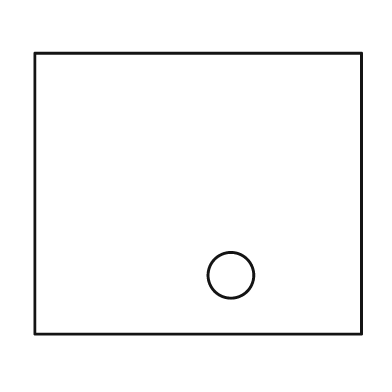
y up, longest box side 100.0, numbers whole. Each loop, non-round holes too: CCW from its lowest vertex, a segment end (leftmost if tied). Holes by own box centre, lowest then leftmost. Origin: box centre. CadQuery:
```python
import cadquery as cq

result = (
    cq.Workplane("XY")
    .moveTo(-50.0, -43.0)
    .lineTo(50.0, -43.0)
    .lineTo(50.0, 43.0)
    .lineTo(-50.0, 43.0)
    .close()
    .moveTo(10.0, -25.0)
    .circle(7.0)
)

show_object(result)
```